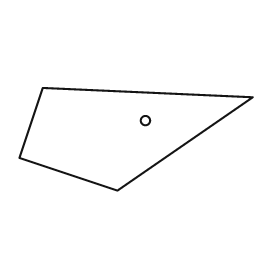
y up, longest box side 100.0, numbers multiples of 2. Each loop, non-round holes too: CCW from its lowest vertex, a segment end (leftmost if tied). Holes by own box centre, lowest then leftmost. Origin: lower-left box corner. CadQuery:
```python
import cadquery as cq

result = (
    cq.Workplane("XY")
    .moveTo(42.0, 0.0)
    .lineTo(100.0, 40.0)
    .lineTo(10.0, 44.0)
    .lineTo(0.0, 14.0)
    .close()
    .moveTo(54.0, 30.0)
    .circle(2.0)
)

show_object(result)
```